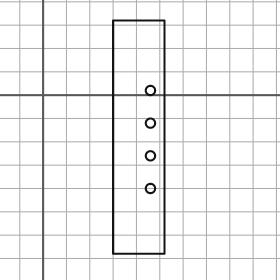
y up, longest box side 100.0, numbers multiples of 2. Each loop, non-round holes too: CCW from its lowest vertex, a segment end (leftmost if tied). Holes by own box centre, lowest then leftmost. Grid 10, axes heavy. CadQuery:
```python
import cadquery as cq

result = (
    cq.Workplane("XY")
    .moveTo(30.0, -68.0)
    .lineTo(52.0, -68.0)
    .lineTo(52.0, 32.0)
    .lineTo(30.0, 32.0)
    .close()
    .moveTo(46.0, -40.0)
    .circle(2.0)
    .moveTo(46.0, -26.0)
    .circle(2.0)
    .moveTo(46.0, -12.0)
    .circle(2.0)
    .moveTo(46.0, 2.0)
    .circle(2.0)
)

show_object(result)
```